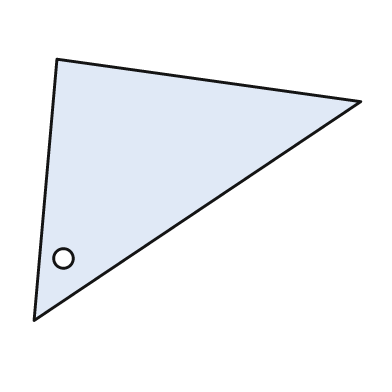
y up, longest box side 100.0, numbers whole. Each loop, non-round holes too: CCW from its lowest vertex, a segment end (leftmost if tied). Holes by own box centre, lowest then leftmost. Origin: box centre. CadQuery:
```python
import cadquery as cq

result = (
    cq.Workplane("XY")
    .moveTo(-50.0, -40.0)
    .lineTo(50.0, 27.0)
    .lineTo(-43.0, 40.0)
    .close()
    .moveTo(-41.0, -21.0)
    .circle(3.0)
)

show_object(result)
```